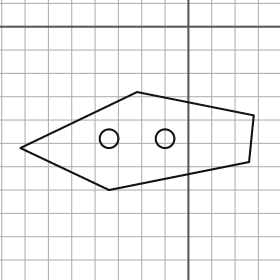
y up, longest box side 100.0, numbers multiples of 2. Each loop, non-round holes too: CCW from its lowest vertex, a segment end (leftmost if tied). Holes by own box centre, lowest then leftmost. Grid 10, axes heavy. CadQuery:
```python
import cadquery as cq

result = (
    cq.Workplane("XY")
    .moveTo(-34.0, -70.0)
    .lineTo(26.0, -58.0)
    .lineTo(28.0, -38.0)
    .lineTo(-22.0, -28.0)
    .lineTo(-72.0, -52.0)
    .close()
    .moveTo(-34.0, -48.0)
    .circle(4.0)
    .moveTo(-10.0, -48.0)
    .circle(4.0)
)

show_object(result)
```